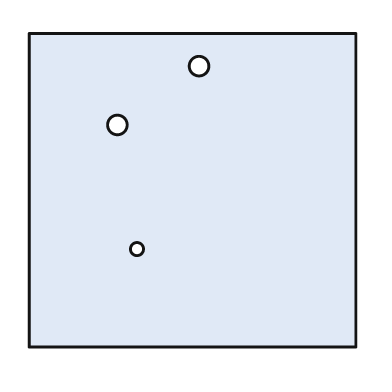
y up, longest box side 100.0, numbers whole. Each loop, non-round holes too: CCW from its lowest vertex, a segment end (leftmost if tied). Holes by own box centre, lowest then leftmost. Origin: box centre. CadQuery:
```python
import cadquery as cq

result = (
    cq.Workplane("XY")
    .moveTo(-50.0, -48.0)
    .lineTo(50.0, -48.0)
    .lineTo(50.0, 48.0)
    .lineTo(-50.0, 48.0)
    .close()
    .moveTo(-17.0, -18.0)
    .circle(2.0)
    .moveTo(-23.0, 20.0)
    .circle(3.0)
    .moveTo(2.0, 38.0)
    .circle(3.0)
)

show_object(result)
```